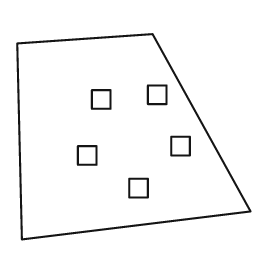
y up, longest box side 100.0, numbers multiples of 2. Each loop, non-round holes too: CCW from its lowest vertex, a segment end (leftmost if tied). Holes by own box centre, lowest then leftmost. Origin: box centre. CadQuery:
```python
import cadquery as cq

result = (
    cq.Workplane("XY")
    .moveTo(-48.0, -44.0)
    .lineTo(50.0, -32.0)
    .lineTo(8.0, 44.0)
    .lineTo(-50.0, 40.0)
    .close()
    .moveTo(-2.0, -26.0)
    .lineTo(6.0, -26.0)
    .lineTo(6.0, -18.0)
    .lineTo(-2.0, -18.0)
    .close()
    .moveTo(-24.0, -12.0)
    .lineTo(-16.0, -12.0)
    .lineTo(-16.0, -4.0)
    .lineTo(-24.0, -4.0)
    .close()
    .moveTo(16.0, -8.0)
    .lineTo(24.0, -8.0)
    .lineTo(24.0, 0.0)
    .lineTo(16.0, 0.0)
    .close()
    .moveTo(-18.0, 12.0)
    .lineTo(-10.0, 12.0)
    .lineTo(-10.0, 20.0)
    .lineTo(-18.0, 20.0)
    .close()
    .moveTo(6.0, 14.0)
    .lineTo(14.0, 14.0)
    .lineTo(14.0, 22.0)
    .lineTo(6.0, 22.0)
    .close()
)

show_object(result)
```